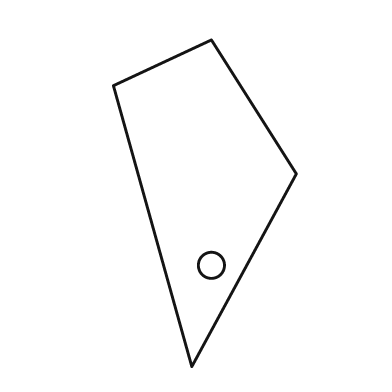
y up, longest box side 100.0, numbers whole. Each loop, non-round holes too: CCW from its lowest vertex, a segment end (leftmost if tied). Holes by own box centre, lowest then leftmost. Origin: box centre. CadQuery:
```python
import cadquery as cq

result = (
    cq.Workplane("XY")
    .moveTo(-4.0, -50.0)
    .lineTo(28.0, 9.0)
    .lineTo(2.0, 50.0)
    .lineTo(-28.0, 36.0)
    .close()
    .moveTo(2.0, -19.0)
    .circle(4.0)
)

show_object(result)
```